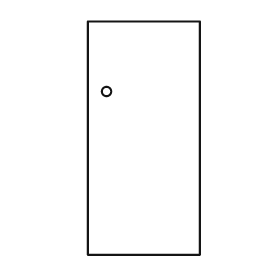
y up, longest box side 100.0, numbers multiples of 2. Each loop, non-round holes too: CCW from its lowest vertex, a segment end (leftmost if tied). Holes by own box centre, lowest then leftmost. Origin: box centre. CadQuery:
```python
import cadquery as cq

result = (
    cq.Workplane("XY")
    .moveTo(-24.0, -50.0)
    .lineTo(24.0, -50.0)
    .lineTo(24.0, 50.0)
    .lineTo(-24.0, 50.0)
    .close()
    .moveTo(-16.0, 20.0)
    .circle(2.0)
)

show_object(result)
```